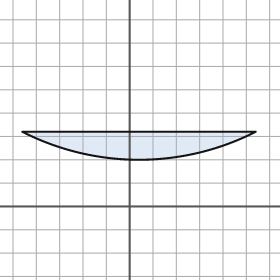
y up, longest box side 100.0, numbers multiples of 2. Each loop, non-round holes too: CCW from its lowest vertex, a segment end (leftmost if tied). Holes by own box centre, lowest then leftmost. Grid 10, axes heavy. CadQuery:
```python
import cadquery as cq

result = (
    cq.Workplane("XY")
    .moveTo(-46.0, 32.0)
    .threePointArc((4.0, 20.0), (54.0, 32.0))
    .close()
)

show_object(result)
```